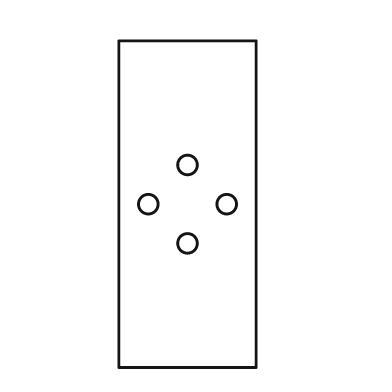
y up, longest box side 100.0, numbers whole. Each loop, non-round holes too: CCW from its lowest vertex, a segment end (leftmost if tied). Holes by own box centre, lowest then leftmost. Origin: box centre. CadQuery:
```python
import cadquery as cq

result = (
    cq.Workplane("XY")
    .moveTo(-21.0, -50.0)
    .lineTo(21.0, -50.0)
    .lineTo(21.0, 50.0)
    .lineTo(-21.0, 50.0)
    .close()
    .moveTo(0.0, -12.0)
    .circle(3.0)
    .moveTo(-12.0, 0.0)
    .circle(3.0)
    .moveTo(12.0, 0.0)
    .circle(3.0)
    .moveTo(0.0, 12.0)
    .circle(3.0)
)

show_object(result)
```